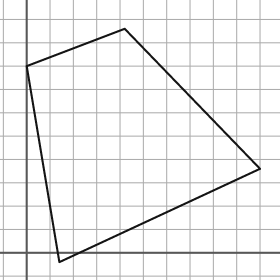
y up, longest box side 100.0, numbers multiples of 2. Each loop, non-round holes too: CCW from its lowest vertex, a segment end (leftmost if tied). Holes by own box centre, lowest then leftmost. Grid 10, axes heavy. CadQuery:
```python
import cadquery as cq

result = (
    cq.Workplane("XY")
    .moveTo(14.0, -4.0)
    .lineTo(100.0, 36.0)
    .lineTo(42.0, 96.0)
    .lineTo(0.0, 80.0)
    .close()
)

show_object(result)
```